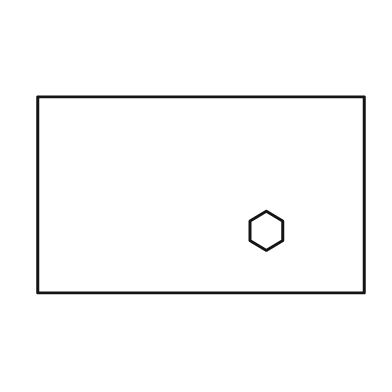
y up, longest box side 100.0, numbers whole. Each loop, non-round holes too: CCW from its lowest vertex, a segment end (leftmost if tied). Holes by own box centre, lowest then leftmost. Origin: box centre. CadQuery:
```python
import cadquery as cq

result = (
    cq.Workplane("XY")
    .moveTo(-50.0, -30.0)
    .lineTo(50.0, -30.0)
    .lineTo(50.0, 30.0)
    .lineTo(-50.0, 30.0)
    .close()
    .moveTo(20.0, -17.0)
    .lineTo(25.0, -14.0)
    .lineTo(25.0, -8.0)
    .lineTo(20.0, -5.0)
    .lineTo(15.0, -8.0)
    .lineTo(15.0, -14.0)
    .close()
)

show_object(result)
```